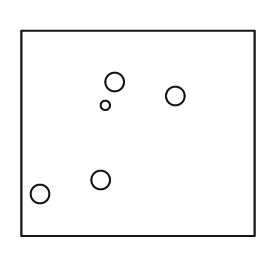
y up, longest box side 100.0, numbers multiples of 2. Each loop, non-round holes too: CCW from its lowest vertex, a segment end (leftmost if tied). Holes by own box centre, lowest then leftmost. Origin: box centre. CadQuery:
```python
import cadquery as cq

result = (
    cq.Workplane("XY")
    .moveTo(-50.0, -44.0)
    .lineTo(50.0, -44.0)
    .lineTo(50.0, 44.0)
    .lineTo(-50.0, 44.0)
    .close()
    .moveTo(-42.0, -26.0)
    .circle(4.0)
    .moveTo(-16.0, -20.0)
    .circle(4.0)
    .moveTo(-14.0, 12.0)
    .circle(2.0)
    .moveTo(16.0, 16.0)
    .circle(4.0)
    .moveTo(-10.0, 22.0)
    .circle(4.0)
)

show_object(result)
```